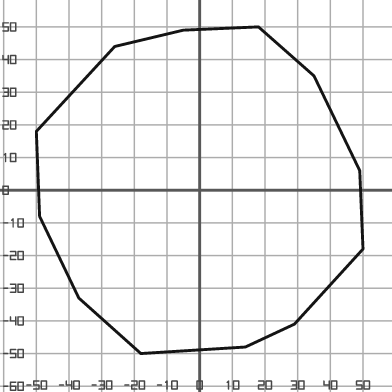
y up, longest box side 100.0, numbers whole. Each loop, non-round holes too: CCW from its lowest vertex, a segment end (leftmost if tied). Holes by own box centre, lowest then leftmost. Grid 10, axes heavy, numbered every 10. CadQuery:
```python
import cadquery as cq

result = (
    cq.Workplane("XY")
    .moveTo(-18.0, -50.0)
    .lineTo(14.0, -48.0)
    .lineTo(29.0, -41.0)
    .lineTo(50.0, -18.0)
    .lineTo(49.0, 6.0)
    .lineTo(35.0, 35.0)
    .lineTo(18.0, 50.0)
    .lineTo(-5.0, 49.0)
    .lineTo(-26.0, 44.0)
    .lineTo(-50.0, 18.0)
    .lineTo(-49.0, -8.0)
    .lineTo(-37.0, -33.0)
    .close()
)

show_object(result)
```